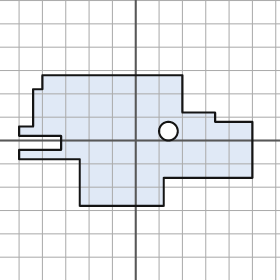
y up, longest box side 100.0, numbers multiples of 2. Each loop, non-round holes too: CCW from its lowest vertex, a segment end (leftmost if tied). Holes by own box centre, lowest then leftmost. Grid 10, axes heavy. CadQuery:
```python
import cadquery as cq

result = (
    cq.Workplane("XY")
    .moveTo(-24.0, -28.0)
    .lineTo(12.0, -28.0)
    .lineTo(12.0, -16.0)
    .lineTo(50.0, -16.0)
    .lineTo(50.0, 8.0)
    .lineTo(34.0, 8.0)
    .lineTo(34.0, 12.0)
    .lineTo(20.0, 12.0)
    .lineTo(20.0, 28.0)
    .lineTo(-40.0, 28.0)
    .lineTo(-40.0, 22.0)
    .lineTo(-44.0, 22.0)
    .lineTo(-44.0, 6.0)
    .lineTo(-50.0, 6.0)
    .lineTo(-50.0, 2.0)
    .lineTo(-32.0, 2.0)
    .lineTo(-32.0, -4.0)
    .lineTo(-50.0, -4.0)
    .lineTo(-50.0, -8.0)
    .lineTo(-24.0, -8.0)
    .close()
    .moveTo(14.0, 4.0)
    .circle(4.0)
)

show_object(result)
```